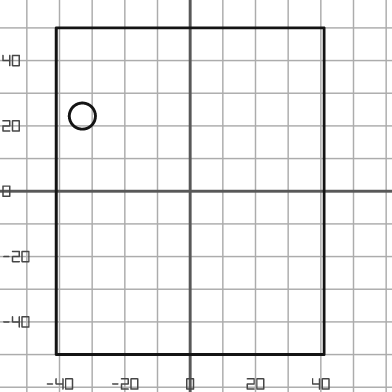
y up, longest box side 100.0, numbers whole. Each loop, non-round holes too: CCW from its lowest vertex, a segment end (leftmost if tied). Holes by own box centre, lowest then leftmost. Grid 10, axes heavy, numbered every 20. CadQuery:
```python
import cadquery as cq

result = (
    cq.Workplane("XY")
    .moveTo(-41.0, -50.0)
    .lineTo(41.0, -50.0)
    .lineTo(41.0, 50.0)
    .lineTo(-41.0, 50.0)
    .close()
    .moveTo(-33.0, 23.0)
    .circle(4.0)
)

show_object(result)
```